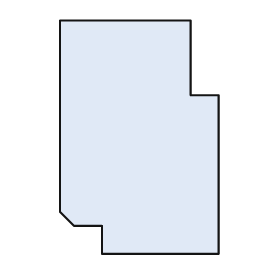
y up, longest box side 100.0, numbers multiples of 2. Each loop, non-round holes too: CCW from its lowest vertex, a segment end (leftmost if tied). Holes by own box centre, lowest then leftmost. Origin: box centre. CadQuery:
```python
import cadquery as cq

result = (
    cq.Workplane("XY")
    .moveTo(-16.0, -50.0)
    .lineTo(34.0, -50.0)
    .lineTo(34.0, 18.0)
    .lineTo(22.0, 18.0)
    .lineTo(22.0, 50.0)
    .lineTo(-34.0, 50.0)
    .lineTo(-34.0, -32.0)
    .lineTo(-28.0, -38.0)
    .lineTo(-16.0, -38.0)
    .close()
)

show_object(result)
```